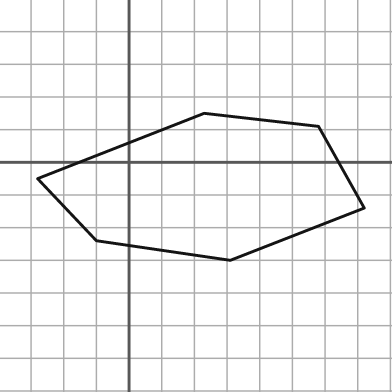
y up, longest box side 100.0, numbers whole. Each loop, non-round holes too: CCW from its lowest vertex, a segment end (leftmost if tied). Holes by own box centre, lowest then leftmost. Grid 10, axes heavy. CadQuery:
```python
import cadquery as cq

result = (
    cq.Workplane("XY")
    .moveTo(31.0, -30.0)
    .lineTo(72.0, -14.0)
    .lineTo(58.0, 11.0)
    .lineTo(23.0, 15.0)
    .lineTo(-28.0, -5.0)
    .lineTo(-10.0, -24.0)
    .close()
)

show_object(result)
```